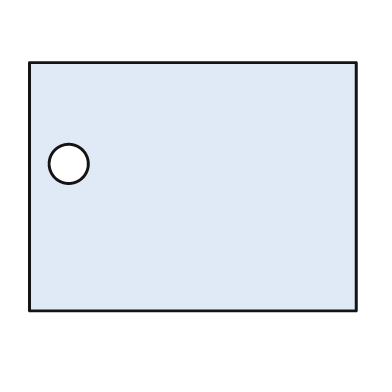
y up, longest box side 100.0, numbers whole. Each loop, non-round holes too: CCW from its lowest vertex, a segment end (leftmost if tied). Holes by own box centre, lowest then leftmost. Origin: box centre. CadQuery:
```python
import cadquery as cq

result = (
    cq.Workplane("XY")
    .moveTo(-50.0, -38.0)
    .lineTo(50.0, -38.0)
    .lineTo(50.0, 38.0)
    .lineTo(-50.0, 38.0)
    .close()
    .moveTo(-38.0, 7.0)
    .circle(6.0)
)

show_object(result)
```